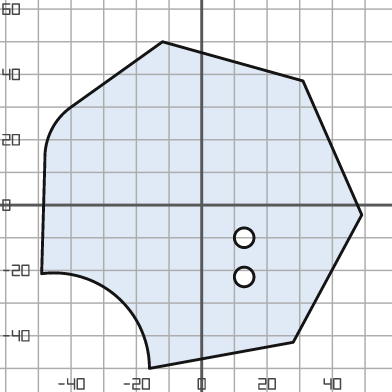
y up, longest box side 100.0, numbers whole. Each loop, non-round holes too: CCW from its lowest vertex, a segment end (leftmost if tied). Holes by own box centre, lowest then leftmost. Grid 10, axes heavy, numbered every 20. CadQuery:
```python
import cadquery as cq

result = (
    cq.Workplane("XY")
    .moveTo(-16.0, -50.0)
    .lineTo(28.0, -42.0)
    .lineTo(49.0, -3.0)
    .lineTo(31.0, 38.0)
    .lineTo(-12.0, 50.0)
    .lineTo(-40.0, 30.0)
    .threePointArc((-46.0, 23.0), (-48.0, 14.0))
    .lineTo(-49.0, -21.0)
    .threePointArc((-26.0, -28.0), (-16.0, -50.0))
    .close()
    .moveTo(13.0, -22.0)
    .circle(3.0)
    .moveTo(13.0, -10.0)
    .circle(3.0)
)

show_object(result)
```